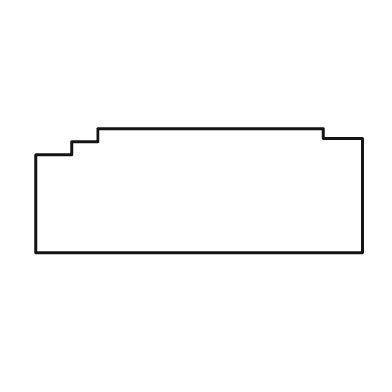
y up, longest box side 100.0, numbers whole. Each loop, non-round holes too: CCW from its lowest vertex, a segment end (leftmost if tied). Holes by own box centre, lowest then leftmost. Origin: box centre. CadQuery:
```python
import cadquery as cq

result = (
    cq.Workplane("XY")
    .moveTo(-50.0, -19.0)
    .lineTo(50.0, -19.0)
    .lineTo(50.0, 16.0)
    .lineTo(38.0, 16.0)
    .lineTo(38.0, 19.0)
    .lineTo(-31.0, 19.0)
    .lineTo(-31.0, 15.0)
    .lineTo(-39.0, 15.0)
    .lineTo(-39.0, 11.0)
    .lineTo(-50.0, 11.0)
    .close()
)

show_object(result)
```